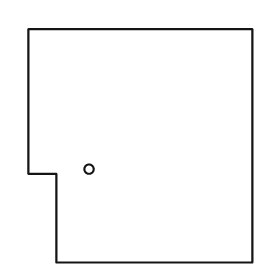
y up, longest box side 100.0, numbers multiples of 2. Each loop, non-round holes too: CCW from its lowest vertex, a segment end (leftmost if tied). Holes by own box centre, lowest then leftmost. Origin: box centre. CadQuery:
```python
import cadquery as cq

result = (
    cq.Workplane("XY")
    .moveTo(-36.0, -50.0)
    .lineTo(48.0, -50.0)
    .lineTo(48.0, 50.0)
    .lineTo(-48.0, 50.0)
    .lineTo(-48.0, -12.0)
    .lineTo(-36.0, -12.0)
    .close()
    .moveTo(-22.0, -10.0)
    .circle(2.0)
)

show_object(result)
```